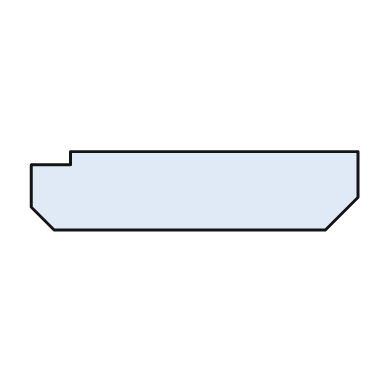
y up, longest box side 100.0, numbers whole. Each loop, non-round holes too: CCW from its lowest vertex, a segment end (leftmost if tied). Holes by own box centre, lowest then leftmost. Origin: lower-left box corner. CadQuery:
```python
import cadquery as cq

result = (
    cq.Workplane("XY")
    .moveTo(7.0, 0.0)
    .lineTo(90.0, 0.0)
    .lineTo(100.0, 10.0)
    .lineTo(100.0, 24.0)
    .lineTo(12.0, 24.0)
    .lineTo(12.0, 20.0)
    .lineTo(0.0, 20.0)
    .lineTo(0.0, 7.0)
    .close()
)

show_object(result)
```